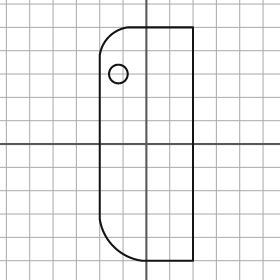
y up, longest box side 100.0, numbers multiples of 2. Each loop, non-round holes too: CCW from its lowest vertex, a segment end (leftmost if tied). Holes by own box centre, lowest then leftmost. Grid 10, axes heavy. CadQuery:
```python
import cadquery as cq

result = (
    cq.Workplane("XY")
    .moveTo(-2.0, -50.0)
    .lineTo(20.0, -50.0)
    .lineTo(20.0, 50.0)
    .lineTo(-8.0, 50.0)
    .threePointArc((-16.0, 46.0), (-20.0, 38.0))
    .lineTo(-20.0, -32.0)
    .threePointArc((-14.0, -44.0), (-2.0, -50.0))
    .close()
    .moveTo(-12.0, 30.0)
    .circle(4.0)
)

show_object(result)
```